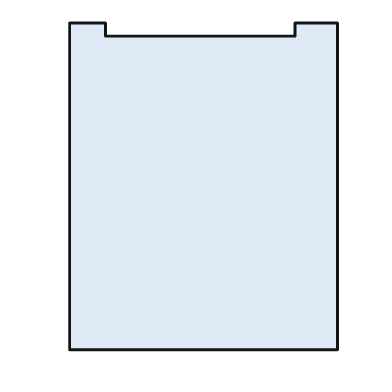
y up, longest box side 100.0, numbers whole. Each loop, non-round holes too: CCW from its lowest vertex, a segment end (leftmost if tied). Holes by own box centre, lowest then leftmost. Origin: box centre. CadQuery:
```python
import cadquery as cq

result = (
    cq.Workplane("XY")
    .moveTo(-41.0, -50.0)
    .lineTo(41.0, -50.0)
    .lineTo(41.0, 50.0)
    .lineTo(28.0, 50.0)
    .lineTo(28.0, 46.0)
    .lineTo(-30.0, 46.0)
    .lineTo(-30.0, 50.0)
    .lineTo(-41.0, 50.0)
    .close()
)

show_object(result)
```